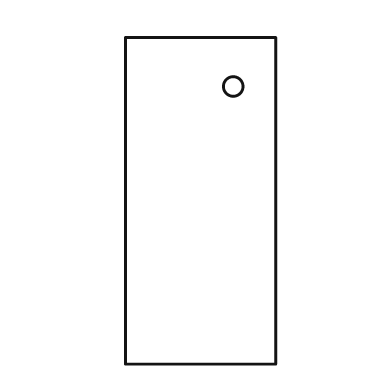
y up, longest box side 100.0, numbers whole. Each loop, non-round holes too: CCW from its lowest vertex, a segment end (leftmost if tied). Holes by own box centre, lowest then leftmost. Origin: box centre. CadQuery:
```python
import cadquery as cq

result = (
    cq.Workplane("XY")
    .moveTo(-23.0, -50.0)
    .lineTo(23.0, -50.0)
    .lineTo(23.0, 50.0)
    .lineTo(-23.0, 50.0)
    .close()
    .moveTo(10.0, 35.0)
    .circle(3.0)
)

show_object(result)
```